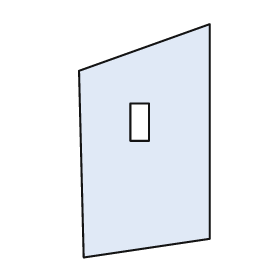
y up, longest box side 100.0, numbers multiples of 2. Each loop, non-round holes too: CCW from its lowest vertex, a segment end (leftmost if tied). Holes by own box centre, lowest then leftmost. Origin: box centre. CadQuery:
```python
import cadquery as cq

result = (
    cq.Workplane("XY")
    .moveTo(-26.0, -50.0)
    .lineTo(28.0, -42.0)
    .lineTo(28.0, 50.0)
    .lineTo(-28.0, 30.0)
    .close()
    .moveTo(-6.0, 0.0)
    .lineTo(2.0, 0.0)
    .lineTo(2.0, 16.0)
    .lineTo(-6.0, 16.0)
    .close()
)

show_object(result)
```